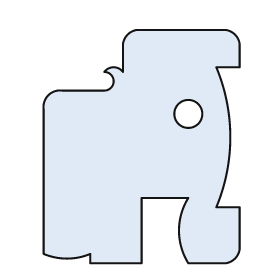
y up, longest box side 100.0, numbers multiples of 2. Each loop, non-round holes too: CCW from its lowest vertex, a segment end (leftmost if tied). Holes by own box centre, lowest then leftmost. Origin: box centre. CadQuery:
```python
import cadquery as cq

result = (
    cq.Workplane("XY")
    .moveTo(-22.0, -50.0)
    .lineTo(0.0, -50.0)
    .lineTo(0.0, -22.0)
    .lineTo(20.0, -22.0)
    .threePointArc((16.0, -36.0), (20.0, -50.0))
    .lineTo(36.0, -50.0)
    .threePointArc((40.0, -48.0), (42.0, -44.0))
    .lineTo(42.0, -26.0)
    .lineTo(32.0, -26.0)
    .threePointArc((38.0, 4.0), (32.0, 34.0))
    .lineTo(42.0, 34.0)
    .lineTo(42.0, 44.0)
    .threePointArc((40.0, 48.0), (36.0, 50.0))
    .lineTo(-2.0, 50.0)
    .threePointArc((-6.0, 48.0), (-8.0, 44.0))
    .lineTo(-8.0, 32.0)
    .threePointArc((-12.0, 34.0), (-16.0, 32.0))
    .threePointArc((-12.0, 28.0), (-16.0, 24.0))
    .lineTo(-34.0, 24.0)
    .threePointArc((-40.0, 22.0), (-42.0, 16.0))
    .lineTo(-42.0, -46.0)
    .threePointArc((-32.0, -48.0), (-22.0, -46.0))
    .close()
    .moveTo(20.0, 14.0)
    .circle(6.0)
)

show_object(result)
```